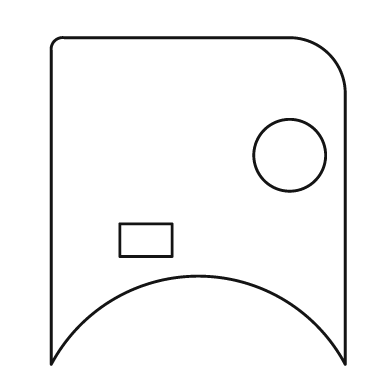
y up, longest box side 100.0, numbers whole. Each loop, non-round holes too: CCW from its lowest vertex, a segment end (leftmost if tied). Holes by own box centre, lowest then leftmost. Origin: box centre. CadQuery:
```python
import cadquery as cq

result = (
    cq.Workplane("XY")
    .moveTo(-45.0, -50.0)
    .threePointArc((0.0, -23.0), (45.0, -50.0))
    .lineTo(45.0, 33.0)
    .threePointArc((40.0, 45.0), (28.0, 50.0))
    .lineTo(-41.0, 50.0)
    .threePointArc((-44.0, 49.0), (-45.0, 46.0))
    .close()
    .moveTo(-24.0, -17.0)
    .lineTo(-8.0, -17.0)
    .lineTo(-8.0, -7.0)
    .lineTo(-24.0, -7.0)
    .close()
    .moveTo(28.0, 14.0)
    .circle(11.0)
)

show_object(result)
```